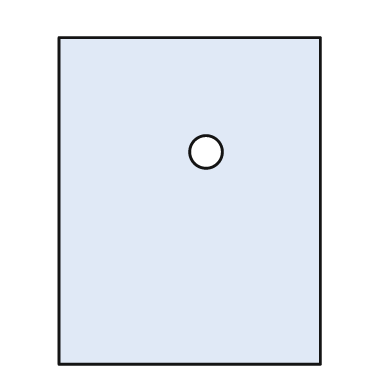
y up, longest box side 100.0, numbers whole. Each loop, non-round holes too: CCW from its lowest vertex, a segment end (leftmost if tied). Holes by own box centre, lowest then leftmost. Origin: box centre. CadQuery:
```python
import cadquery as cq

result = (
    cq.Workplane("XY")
    .moveTo(-40.0, -50.0)
    .lineTo(40.0, -50.0)
    .lineTo(40.0, 50.0)
    .lineTo(-40.0, 50.0)
    .close()
    .moveTo(5.0, 15.0)
    .circle(5.0)
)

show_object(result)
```